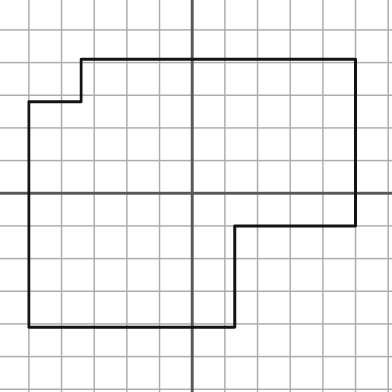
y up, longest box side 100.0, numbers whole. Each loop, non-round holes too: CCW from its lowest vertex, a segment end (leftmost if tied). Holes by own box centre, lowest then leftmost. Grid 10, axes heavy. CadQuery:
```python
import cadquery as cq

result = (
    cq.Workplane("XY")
    .moveTo(-50.0, -41.0)
    .lineTo(13.0, -41.0)
    .lineTo(13.0, -10.0)
    .lineTo(50.0, -10.0)
    .lineTo(50.0, 41.0)
    .lineTo(-34.0, 41.0)
    .lineTo(-34.0, 28.0)
    .lineTo(-50.0, 28.0)
    .close()
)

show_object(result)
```